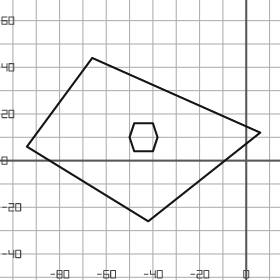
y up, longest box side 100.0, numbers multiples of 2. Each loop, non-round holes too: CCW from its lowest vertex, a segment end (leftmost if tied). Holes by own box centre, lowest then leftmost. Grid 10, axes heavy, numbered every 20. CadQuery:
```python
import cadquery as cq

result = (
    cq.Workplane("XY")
    .moveTo(-42.0, -26.0)
    .lineTo(6.0, 12.0)
    .lineTo(-66.0, 44.0)
    .lineTo(-94.0, 6.0)
    .close()
    .moveTo(-48.0, 4.0)
    .lineTo(-40.0, 4.0)
    .lineTo(-38.0, 10.0)
    .lineTo(-40.0, 16.0)
    .lineTo(-48.0, 16.0)
    .lineTo(-50.0, 10.0)
    .close()
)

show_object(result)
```